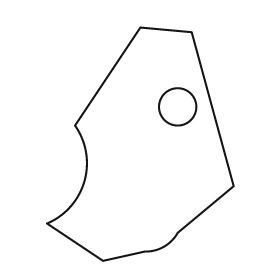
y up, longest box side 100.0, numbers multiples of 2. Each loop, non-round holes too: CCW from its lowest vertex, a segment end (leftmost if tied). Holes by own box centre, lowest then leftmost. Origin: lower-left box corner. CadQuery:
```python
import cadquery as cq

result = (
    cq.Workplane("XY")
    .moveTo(24.0, 0.0)
    .lineTo(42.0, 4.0)
    .threePointArc((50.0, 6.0), (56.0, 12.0))
    .lineTo(80.0, 32.0)
    .lineTo(62.0, 98.0)
    .lineTo(40.0, 100.0)
    .lineTo(12.0, 58.0)
    .threePointArc((16.0, 34.0), (0.0, 16.0))
    .close()
    .moveTo(56.0, 66.0)
    .circle(8.0)
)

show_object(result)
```